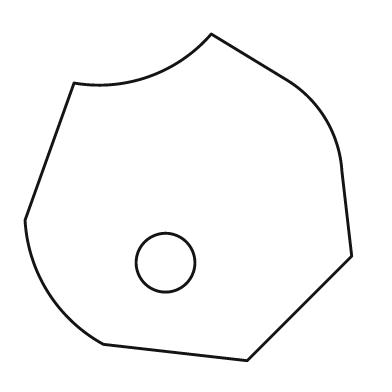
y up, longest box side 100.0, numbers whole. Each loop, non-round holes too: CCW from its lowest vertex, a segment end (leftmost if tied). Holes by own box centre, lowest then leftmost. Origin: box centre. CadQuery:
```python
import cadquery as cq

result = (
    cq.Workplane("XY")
    .moveTo(18.0, -50.0)
    .lineTo(50.0, -18.0)
    .lineTo(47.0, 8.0)
    .threePointArc((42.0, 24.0), (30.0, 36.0))
    .lineTo(7.0, 50.0)
    .threePointArc((-12.0, 37.0), (-35.0, 35.0))
    .lineTo(-50.0, -7.0)
    .threePointArc((-43.0, -29.0), (-26.0, -45.0))
    .close()
    .moveTo(-7.0, -20.0)
    .circle(9.0)
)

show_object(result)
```